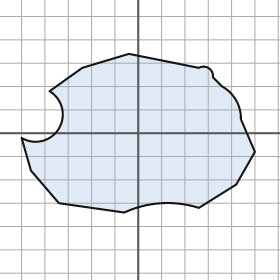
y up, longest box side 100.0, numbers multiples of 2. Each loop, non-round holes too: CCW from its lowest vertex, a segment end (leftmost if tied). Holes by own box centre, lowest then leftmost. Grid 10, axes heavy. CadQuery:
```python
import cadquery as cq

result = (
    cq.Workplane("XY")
    .moveTo(-6.0, -34.0)
    .threePointArc((10.0, -30.0), (26.0, -32.0))
    .lineTo(42.0, -22.0)
    .lineTo(50.0, -8.0)
    .lineTo(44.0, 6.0)
    .threePointArc((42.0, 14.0), (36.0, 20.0))
    .lineTo(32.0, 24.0)
    .threePointArc((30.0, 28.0), (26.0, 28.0))
    .lineTo(-4.0, 34.0)
    .lineTo(-24.0, 28.0)
    .lineTo(-38.0, 18.0)
    .threePointArc((-34.0, 2.0), (-50.0, -2.0))
    .lineTo(-46.0, -16.0)
    .lineTo(-34.0, -30.0)
    .close()
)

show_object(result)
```